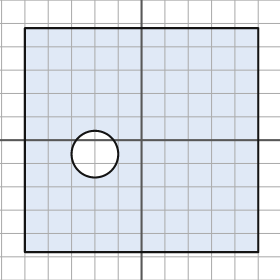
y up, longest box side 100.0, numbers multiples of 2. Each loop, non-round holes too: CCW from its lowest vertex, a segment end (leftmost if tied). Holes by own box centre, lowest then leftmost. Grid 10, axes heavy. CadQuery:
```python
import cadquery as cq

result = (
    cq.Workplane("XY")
    .moveTo(-50.0, -48.0)
    .lineTo(50.0, -48.0)
    .lineTo(50.0, 48.0)
    .lineTo(-50.0, 48.0)
    .close()
    .moveTo(-20.0, -6.0)
    .circle(10.0)
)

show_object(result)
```